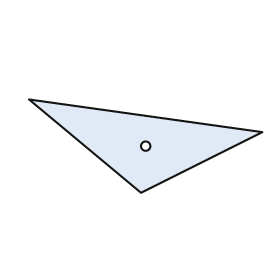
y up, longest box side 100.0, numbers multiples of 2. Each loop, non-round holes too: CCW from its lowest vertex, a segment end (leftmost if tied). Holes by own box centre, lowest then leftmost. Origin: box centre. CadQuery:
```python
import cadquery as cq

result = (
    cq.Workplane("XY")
    .moveTo(-2.0, -20.0)
    .lineTo(50.0, 6.0)
    .lineTo(-50.0, 20.0)
    .close()
    .moveTo(0.0, 0.0)
    .circle(2.0)
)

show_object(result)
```